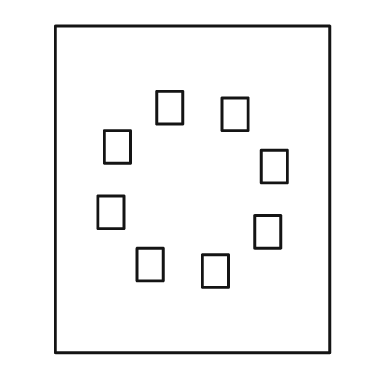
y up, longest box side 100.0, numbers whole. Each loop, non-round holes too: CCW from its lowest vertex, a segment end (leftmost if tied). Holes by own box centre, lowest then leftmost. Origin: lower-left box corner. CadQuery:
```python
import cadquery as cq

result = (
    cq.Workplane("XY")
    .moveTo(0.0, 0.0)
    .lineTo(84.0, 0.0)
    .lineTo(84.0, 100.0)
    .lineTo(0.0, 100.0)
    .close()
    .moveTo(45.0, 20.0)
    .lineTo(53.0, 20.0)
    .lineTo(53.0, 30.0)
    .lineTo(45.0, 30.0)
    .close()
    .moveTo(25.0, 22.0)
    .lineTo(33.0, 22.0)
    .lineTo(33.0, 32.0)
    .lineTo(25.0, 32.0)
    .close()
    .moveTo(61.0, 32.0)
    .lineTo(69.0, 32.0)
    .lineTo(69.0, 42.0)
    .lineTo(61.0, 42.0)
    .close()
    .moveTo(13.0, 38.0)
    .lineTo(21.0, 38.0)
    .lineTo(21.0, 48.0)
    .lineTo(13.0, 48.0)
    .close()
    .moveTo(63.0, 52.0)
    .lineTo(71.0, 52.0)
    .lineTo(71.0, 62.0)
    .lineTo(63.0, 62.0)
    .close()
    .moveTo(15.0, 58.0)
    .lineTo(23.0, 58.0)
    .lineTo(23.0, 68.0)
    .lineTo(15.0, 68.0)
    .close()
    .moveTo(51.0, 68.0)
    .lineTo(59.0, 68.0)
    .lineTo(59.0, 78.0)
    .lineTo(51.0, 78.0)
    .close()
    .moveTo(31.0, 70.0)
    .lineTo(39.0, 70.0)
    .lineTo(39.0, 80.0)
    .lineTo(31.0, 80.0)
    .close()
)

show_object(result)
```